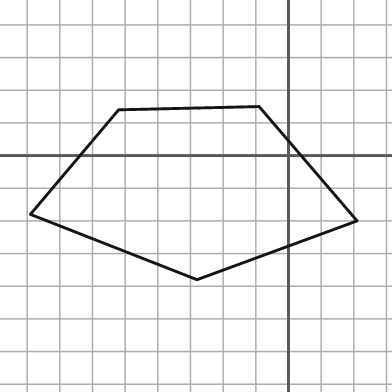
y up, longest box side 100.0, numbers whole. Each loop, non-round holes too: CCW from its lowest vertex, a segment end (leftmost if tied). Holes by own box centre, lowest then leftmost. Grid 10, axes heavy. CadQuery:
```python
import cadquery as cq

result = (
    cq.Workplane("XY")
    .moveTo(-28.0, -38.0)
    .lineTo(21.0, -20.0)
    .lineTo(-9.0, 15.0)
    .lineTo(-52.0, 14.0)
    .lineTo(-79.0, -18.0)
    .close()
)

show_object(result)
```